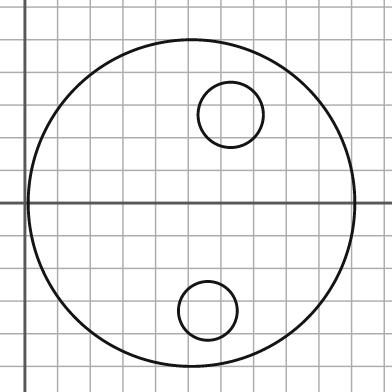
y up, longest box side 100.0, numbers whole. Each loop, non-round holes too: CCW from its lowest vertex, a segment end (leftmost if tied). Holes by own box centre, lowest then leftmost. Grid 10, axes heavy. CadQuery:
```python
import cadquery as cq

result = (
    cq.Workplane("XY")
    .moveTo(51.0, 0.0)
    .circle(50.0)
    .moveTo(56.0, -33.0)
    .circle(9.0)
    .moveTo(63.0, 27.0)
    .circle(10.0)
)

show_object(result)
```